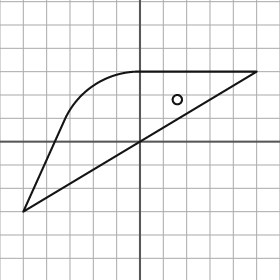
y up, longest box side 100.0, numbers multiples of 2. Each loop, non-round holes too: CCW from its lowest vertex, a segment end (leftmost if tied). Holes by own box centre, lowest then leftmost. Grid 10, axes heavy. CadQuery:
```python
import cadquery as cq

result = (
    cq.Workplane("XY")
    .moveTo(-50.0, -30.0)
    .lineTo(50.0, 30.0)
    .lineTo(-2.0, 30.0)
    .threePointArc((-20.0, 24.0), (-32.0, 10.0))
    .close()
    .moveTo(16.0, 18.0)
    .circle(2.0)
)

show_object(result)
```